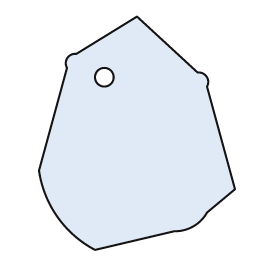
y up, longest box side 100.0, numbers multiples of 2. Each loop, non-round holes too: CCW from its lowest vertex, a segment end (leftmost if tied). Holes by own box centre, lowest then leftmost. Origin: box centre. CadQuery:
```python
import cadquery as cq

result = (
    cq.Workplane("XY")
    .moveTo(-18.0, -50.0)
    .lineTo(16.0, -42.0)
    .threePointArc((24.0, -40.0), (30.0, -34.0))
    .lineTo(42.0, -24.0)
    .lineTo(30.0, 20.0)
    .threePointArc((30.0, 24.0), (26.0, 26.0))
    .lineTo(0.0, 50.0)
    .lineTo(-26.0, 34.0)
    .threePointArc((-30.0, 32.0), (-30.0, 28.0))
    .lineTo(-42.0, -16.0)
    .threePointArc((-34.0, -36.0), (-18.0, -50.0))
    .close()
    .moveTo(-14.0, 24.0)
    .circle(4.0)
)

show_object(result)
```